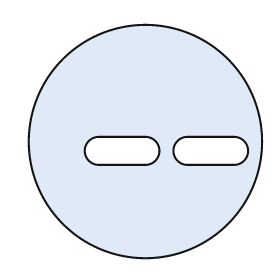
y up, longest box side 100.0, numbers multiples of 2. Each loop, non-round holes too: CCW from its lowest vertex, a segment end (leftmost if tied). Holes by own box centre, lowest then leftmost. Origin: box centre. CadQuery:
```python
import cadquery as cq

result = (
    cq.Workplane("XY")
    .moveTo(0.0, 0.0)
    .circle(50.0)
    .moveTo(-20.0, -10.0)
    .lineTo(0.0, -10.0)
    .threePointArc((6.0, -4.0), (0.0, 2.0))
    .lineTo(-20.0, 2.0)
    .threePointArc((-26.0, -4.0), (-20.0, -10.0))
    .close()
    .moveTo(18.0, -10.0)
    .lineTo(38.0, -10.0)
    .threePointArc((44.0, -4.0), (38.0, 2.0))
    .lineTo(18.0, 2.0)
    .threePointArc((12.0, -4.0), (18.0, -10.0))
    .close()
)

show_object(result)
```